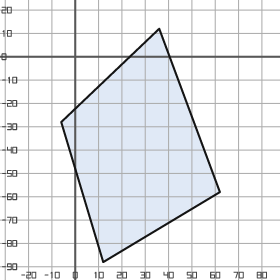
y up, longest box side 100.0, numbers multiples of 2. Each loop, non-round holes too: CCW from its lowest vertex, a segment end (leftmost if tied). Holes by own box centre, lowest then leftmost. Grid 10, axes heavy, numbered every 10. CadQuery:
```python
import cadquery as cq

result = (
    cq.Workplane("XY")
    .moveTo(12.0, -88.0)
    .lineTo(62.0, -58.0)
    .lineTo(36.0, 12.0)
    .lineTo(-6.0, -28.0)
    .close()
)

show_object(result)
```